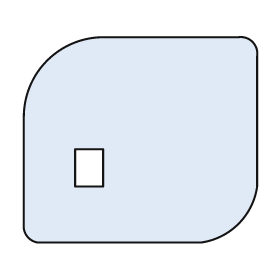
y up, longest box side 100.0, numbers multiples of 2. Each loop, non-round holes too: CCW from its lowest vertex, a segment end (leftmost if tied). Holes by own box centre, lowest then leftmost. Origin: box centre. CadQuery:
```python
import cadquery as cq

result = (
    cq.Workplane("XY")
    .moveTo(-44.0, -44.0)
    .lineTo(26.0, -44.0)
    .threePointArc((42.0, -36.0), (50.0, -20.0))
    .lineTo(50.0, 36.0)
    .threePointArc((48.0, 42.0), (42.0, 44.0))
    .lineTo(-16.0, 44.0)
    .threePointArc((-40.0, 34.0), (-50.0, 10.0))
    .lineTo(-50.0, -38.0)
    .threePointArc((-48.0, -42.0), (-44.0, -44.0))
    .close()
    .moveTo(-28.0, -20.0)
    .lineTo(-16.0, -20.0)
    .lineTo(-16.0, -4.0)
    .lineTo(-28.0, -4.0)
    .close()
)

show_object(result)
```